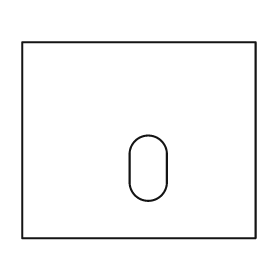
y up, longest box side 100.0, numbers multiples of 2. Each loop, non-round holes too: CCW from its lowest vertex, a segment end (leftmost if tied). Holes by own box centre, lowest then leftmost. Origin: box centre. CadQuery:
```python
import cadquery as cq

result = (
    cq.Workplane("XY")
    .moveTo(-50.0, -42.0)
    .lineTo(50.0, -42.0)
    .lineTo(50.0, 42.0)
    .lineTo(-50.0, 42.0)
    .close()
    .moveTo(-4.0, -18.0)
    .threePointArc((4.0, -26.0), (12.0, -18.0))
    .lineTo(12.0, -6.0)
    .threePointArc((4.0, 2.0), (-4.0, -6.0))
    .close()
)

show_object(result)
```